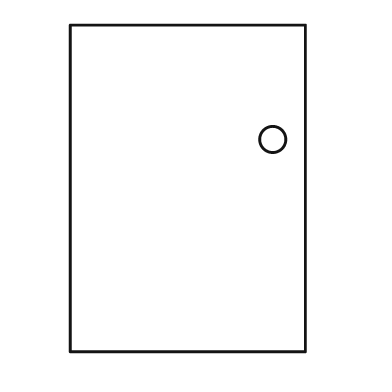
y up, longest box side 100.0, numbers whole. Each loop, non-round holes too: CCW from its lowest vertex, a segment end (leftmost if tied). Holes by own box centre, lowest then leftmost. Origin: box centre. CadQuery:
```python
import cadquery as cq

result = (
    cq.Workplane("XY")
    .moveTo(-36.0, -50.0)
    .lineTo(36.0, -50.0)
    .lineTo(36.0, 50.0)
    .lineTo(-36.0, 50.0)
    .close()
    .moveTo(26.0, 15.0)
    .circle(4.0)
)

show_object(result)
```